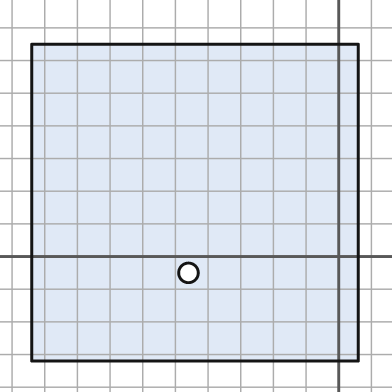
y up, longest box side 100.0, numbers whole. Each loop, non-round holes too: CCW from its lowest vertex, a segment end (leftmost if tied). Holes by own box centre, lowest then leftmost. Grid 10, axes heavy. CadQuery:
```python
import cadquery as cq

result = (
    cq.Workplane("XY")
    .moveTo(-94.0, -32.0)
    .lineTo(6.0, -32.0)
    .lineTo(6.0, 65.0)
    .lineTo(-94.0, 65.0)
    .close()
    .moveTo(-46.0, -5.0)
    .circle(3.0)
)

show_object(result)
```